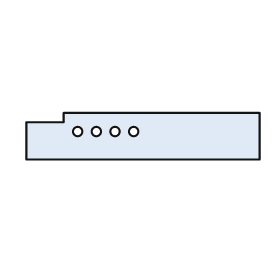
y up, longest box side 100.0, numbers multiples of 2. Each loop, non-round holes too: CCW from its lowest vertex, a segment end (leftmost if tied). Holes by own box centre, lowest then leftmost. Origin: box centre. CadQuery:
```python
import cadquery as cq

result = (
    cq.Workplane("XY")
    .moveTo(-50.0, -10.0)
    .lineTo(50.0, -10.0)
    .lineTo(50.0, 10.0)
    .lineTo(-34.0, 10.0)
    .lineTo(-34.0, 6.0)
    .lineTo(-50.0, 6.0)
    .close()
    .moveTo(-28.0, 2.0)
    .circle(2.0)
    .moveTo(-20.0, 2.0)
    .circle(2.0)
    .moveTo(-12.0, 2.0)
    .circle(2.0)
    .moveTo(-4.0, 2.0)
    .circle(2.0)
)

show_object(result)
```